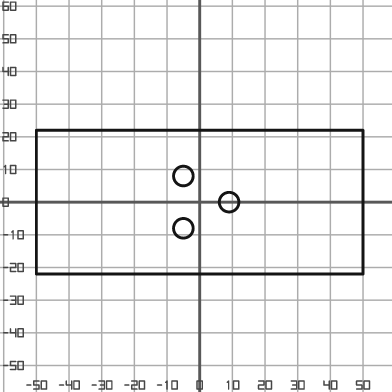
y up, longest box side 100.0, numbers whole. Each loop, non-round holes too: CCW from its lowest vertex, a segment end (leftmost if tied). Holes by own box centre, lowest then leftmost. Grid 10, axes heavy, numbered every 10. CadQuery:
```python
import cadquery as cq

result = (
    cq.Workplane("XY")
    .moveTo(-50.0, -22.0)
    .lineTo(50.0, -22.0)
    .lineTo(50.0, 22.0)
    .lineTo(-50.0, 22.0)
    .close()
    .moveTo(-5.0, -8.0)
    .circle(3.0)
    .moveTo(9.0, 0.0)
    .circle(3.0)
    .moveTo(-5.0, 8.0)
    .circle(3.0)
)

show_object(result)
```